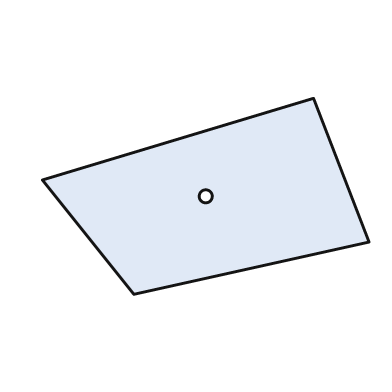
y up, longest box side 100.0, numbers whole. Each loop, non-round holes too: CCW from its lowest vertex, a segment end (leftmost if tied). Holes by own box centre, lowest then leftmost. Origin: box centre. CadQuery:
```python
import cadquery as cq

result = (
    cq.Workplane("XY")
    .moveTo(-22.0, -30.0)
    .lineTo(50.0, -14.0)
    .lineTo(33.0, 30.0)
    .lineTo(-50.0, 5.0)
    .close()
    .moveTo(0.0, 0.0)
    .circle(2.0)
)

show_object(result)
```